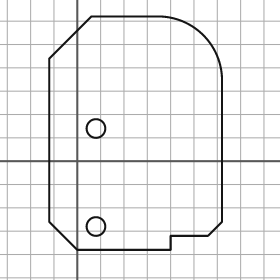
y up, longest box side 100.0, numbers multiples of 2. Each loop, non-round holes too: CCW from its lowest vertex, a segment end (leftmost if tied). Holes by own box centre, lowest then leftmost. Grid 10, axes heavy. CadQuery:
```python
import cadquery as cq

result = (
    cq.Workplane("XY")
    .moveTo(0.0, -38.0)
    .lineTo(40.0, -38.0)
    .lineTo(40.0, -32.0)
    .lineTo(56.0, -32.0)
    .lineTo(62.0, -26.0)
    .lineTo(62.0, 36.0)
    .threePointArc((54.0, 54.0), (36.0, 62.0))
    .lineTo(6.0, 62.0)
    .lineTo(-12.0, 44.0)
    .lineTo(-12.0, -26.0)
    .close()
    .moveTo(8.0, -28.0)
    .circle(4.0)
    .moveTo(8.0, 14.0)
    .circle(4.0)
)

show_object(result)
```